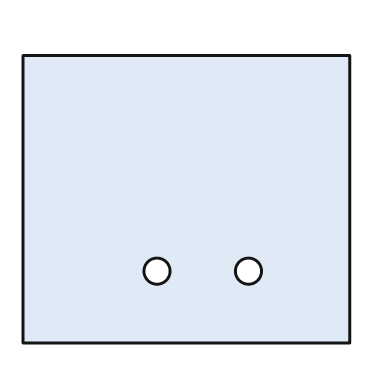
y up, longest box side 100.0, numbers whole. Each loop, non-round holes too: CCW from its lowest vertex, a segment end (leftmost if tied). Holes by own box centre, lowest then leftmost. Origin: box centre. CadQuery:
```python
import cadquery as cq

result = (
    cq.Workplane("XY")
    .moveTo(-50.0, -44.0)
    .lineTo(50.0, -44.0)
    .lineTo(50.0, 44.0)
    .lineTo(-50.0, 44.0)
    .close()
    .moveTo(-9.0, -22.0)
    .circle(4.0)
    .moveTo(19.0, -22.0)
    .circle(4.0)
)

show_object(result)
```